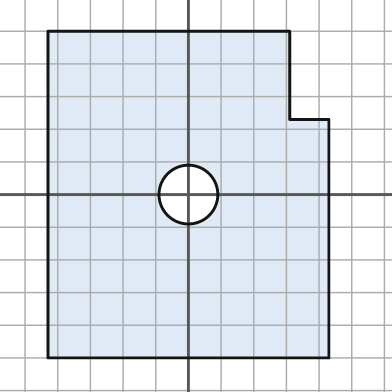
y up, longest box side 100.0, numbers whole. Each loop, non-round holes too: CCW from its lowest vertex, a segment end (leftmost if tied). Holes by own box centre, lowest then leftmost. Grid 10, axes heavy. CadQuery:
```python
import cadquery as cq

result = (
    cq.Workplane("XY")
    .moveTo(-43.0, -50.0)
    .lineTo(43.0, -50.0)
    .lineTo(43.0, 23.0)
    .lineTo(31.0, 23.0)
    .lineTo(31.0, 50.0)
    .lineTo(-43.0, 50.0)
    .close()
    .moveTo(0.0, 0.0)
    .circle(9.0)
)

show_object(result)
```